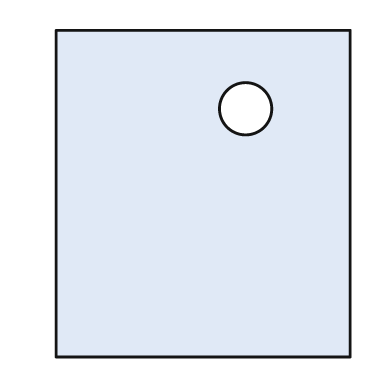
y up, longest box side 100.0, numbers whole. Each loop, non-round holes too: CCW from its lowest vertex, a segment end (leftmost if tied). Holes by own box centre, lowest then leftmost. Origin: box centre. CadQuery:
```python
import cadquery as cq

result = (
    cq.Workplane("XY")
    .moveTo(-45.0, -50.0)
    .lineTo(45.0, -50.0)
    .lineTo(45.0, 50.0)
    .lineTo(-45.0, 50.0)
    .close()
    .moveTo(13.0, 26.0)
    .circle(8.0)
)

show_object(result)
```